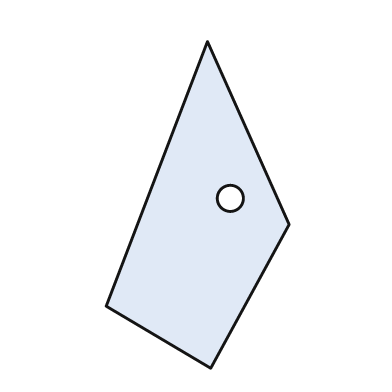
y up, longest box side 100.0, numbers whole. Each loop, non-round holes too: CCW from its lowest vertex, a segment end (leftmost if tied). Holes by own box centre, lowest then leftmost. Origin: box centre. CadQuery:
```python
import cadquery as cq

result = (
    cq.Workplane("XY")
    .moveTo(4.0, -50.0)
    .lineTo(28.0, -6.0)
    .lineTo(3.0, 50.0)
    .lineTo(-28.0, -31.0)
    .close()
    .moveTo(10.0, 2.0)
    .circle(4.0)
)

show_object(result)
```